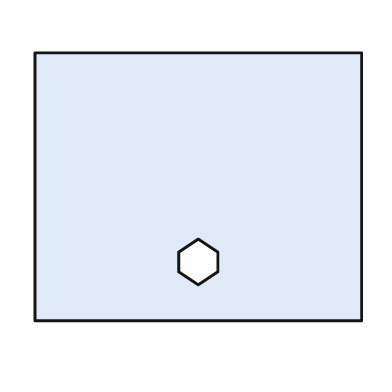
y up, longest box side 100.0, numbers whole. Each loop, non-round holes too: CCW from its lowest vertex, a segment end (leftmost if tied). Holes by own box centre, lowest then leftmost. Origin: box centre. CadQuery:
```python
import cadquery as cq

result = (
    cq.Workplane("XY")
    .moveTo(-50.0, -41.0)
    .lineTo(50.0, -41.0)
    .lineTo(50.0, 41.0)
    .lineTo(-50.0, 41.0)
    .close()
    .moveTo(0.0, -30.0)
    .lineTo(6.0, -26.0)
    .lineTo(6.0, -20.0)
    .lineTo(0.0, -16.0)
    .lineTo(-6.0, -20.0)
    .lineTo(-6.0, -26.0)
    .close()
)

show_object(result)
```